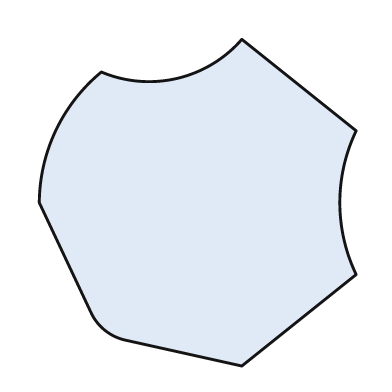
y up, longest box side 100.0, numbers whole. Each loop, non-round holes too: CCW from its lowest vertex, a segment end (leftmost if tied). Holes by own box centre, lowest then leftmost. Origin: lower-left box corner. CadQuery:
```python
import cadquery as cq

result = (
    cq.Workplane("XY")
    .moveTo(62.0, 0.0)
    .lineTo(97.0, 28.0)
    .threePointArc((92.0, 50.0), (97.0, 72.0))
    .lineTo(62.0, 100.0)
    .threePointArc((42.0, 88.0), (19.0, 90.0))
    .threePointArc((5.0, 72.0), (0.0, 50.0))
    .lineTo(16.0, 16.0)
    .threePointArc((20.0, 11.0), (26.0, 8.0))
    .close()
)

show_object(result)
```